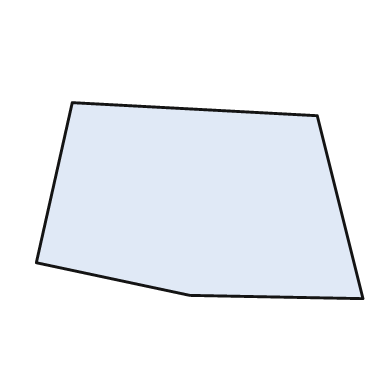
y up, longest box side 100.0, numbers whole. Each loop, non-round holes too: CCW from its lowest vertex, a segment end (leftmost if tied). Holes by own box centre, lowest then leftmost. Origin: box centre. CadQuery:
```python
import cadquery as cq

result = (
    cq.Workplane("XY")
    .moveTo(50.0, -30.0)
    .lineTo(36.0, 26.0)
    .lineTo(-39.0, 30.0)
    .lineTo(-50.0, -19.0)
    .lineTo(-3.0, -29.0)
    .close()
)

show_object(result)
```